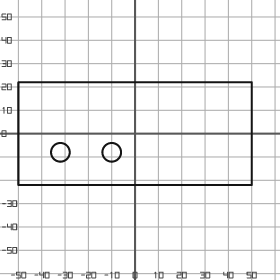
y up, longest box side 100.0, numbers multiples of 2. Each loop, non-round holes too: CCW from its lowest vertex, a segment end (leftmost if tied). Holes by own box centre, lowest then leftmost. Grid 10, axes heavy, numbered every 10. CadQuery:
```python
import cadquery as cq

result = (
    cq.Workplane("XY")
    .moveTo(-50.0, -22.0)
    .lineTo(50.0, -22.0)
    .lineTo(50.0, 22.0)
    .lineTo(-50.0, 22.0)
    .close()
    .moveTo(-32.0, -8.0)
    .circle(4.0)
    .moveTo(-10.0, -8.0)
    .circle(4.0)
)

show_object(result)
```